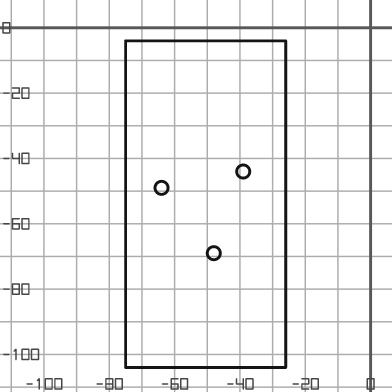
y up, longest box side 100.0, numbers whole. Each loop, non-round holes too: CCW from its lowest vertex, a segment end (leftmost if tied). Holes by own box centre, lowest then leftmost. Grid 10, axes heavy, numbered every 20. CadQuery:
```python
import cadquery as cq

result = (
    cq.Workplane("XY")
    .moveTo(-75.0, -104.0)
    .lineTo(-26.0, -104.0)
    .lineTo(-26.0, -4.0)
    .lineTo(-75.0, -4.0)
    .close()
    .moveTo(-48.0, -69.0)
    .circle(2.0)
    .moveTo(-64.0, -49.0)
    .circle(2.0)
    .moveTo(-39.0, -44.0)
    .circle(2.0)
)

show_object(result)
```